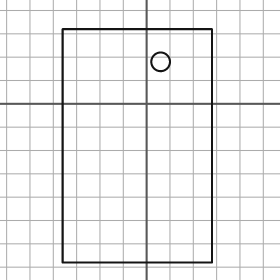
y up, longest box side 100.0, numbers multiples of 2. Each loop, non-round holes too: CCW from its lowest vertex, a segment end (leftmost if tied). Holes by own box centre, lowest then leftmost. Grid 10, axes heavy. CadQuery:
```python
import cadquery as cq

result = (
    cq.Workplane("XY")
    .moveTo(-36.0, -68.0)
    .lineTo(28.0, -68.0)
    .lineTo(28.0, 32.0)
    .lineTo(-36.0, 32.0)
    .close()
    .moveTo(6.0, 18.0)
    .circle(4.0)
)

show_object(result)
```